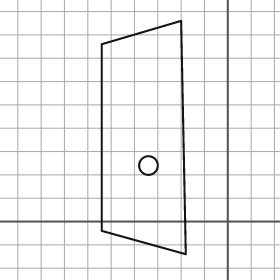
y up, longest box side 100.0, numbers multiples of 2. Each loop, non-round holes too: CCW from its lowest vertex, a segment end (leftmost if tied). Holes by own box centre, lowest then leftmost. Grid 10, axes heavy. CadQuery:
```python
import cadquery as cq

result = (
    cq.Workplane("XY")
    .moveTo(-18.0, -14.0)
    .lineTo(-20.0, 86.0)
    .lineTo(-54.0, 76.0)
    .lineTo(-54.0, -4.0)
    .close()
    .moveTo(-34.0, 24.0)
    .circle(4.0)
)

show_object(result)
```